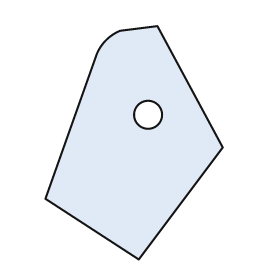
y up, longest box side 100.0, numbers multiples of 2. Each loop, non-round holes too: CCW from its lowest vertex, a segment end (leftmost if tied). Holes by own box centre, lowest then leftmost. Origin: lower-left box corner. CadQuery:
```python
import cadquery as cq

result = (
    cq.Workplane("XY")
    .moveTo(40.0, 0.0)
    .lineTo(76.0, 48.0)
    .lineTo(48.0, 100.0)
    .lineTo(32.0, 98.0)
    .threePointArc((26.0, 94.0), (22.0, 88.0))
    .lineTo(0.0, 26.0)
    .close()
    .moveTo(44.0, 62.0)
    .circle(6.0)
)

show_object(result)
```